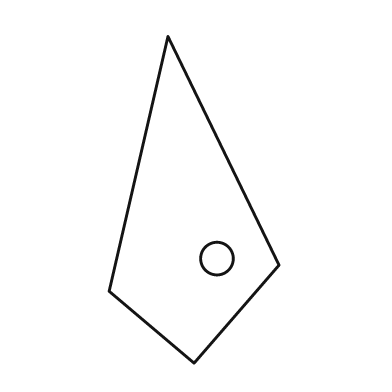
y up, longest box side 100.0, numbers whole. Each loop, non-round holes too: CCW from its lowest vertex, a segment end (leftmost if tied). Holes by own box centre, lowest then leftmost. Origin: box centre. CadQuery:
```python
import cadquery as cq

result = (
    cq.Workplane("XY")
    .moveTo(0.0, -50.0)
    .lineTo(26.0, -20.0)
    .lineTo(-8.0, 50.0)
    .lineTo(-26.0, -28.0)
    .close()
    .moveTo(7.0, -18.0)
    .circle(5.0)
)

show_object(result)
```